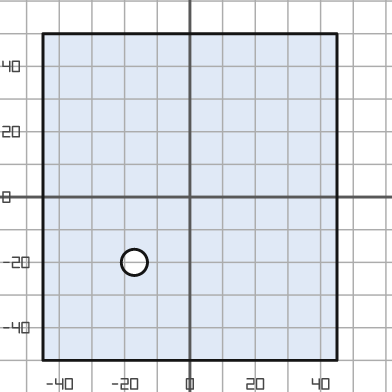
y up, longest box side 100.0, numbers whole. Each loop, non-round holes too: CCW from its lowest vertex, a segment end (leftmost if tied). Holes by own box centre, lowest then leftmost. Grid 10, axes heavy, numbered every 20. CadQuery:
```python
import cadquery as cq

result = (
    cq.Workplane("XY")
    .moveTo(-45.0, -50.0)
    .lineTo(45.0, -50.0)
    .lineTo(45.0, 50.0)
    .lineTo(-45.0, 50.0)
    .close()
    .moveTo(-17.0, -20.0)
    .circle(4.0)
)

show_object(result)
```